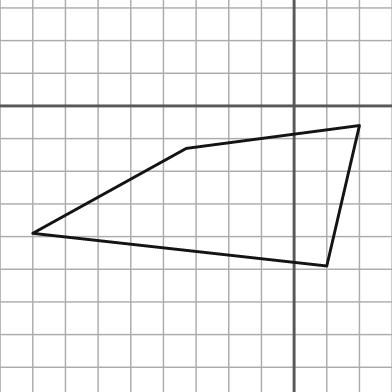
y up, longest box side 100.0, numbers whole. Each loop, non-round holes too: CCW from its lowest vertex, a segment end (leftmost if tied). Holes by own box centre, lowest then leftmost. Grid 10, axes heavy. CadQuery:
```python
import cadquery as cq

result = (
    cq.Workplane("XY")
    .moveTo(10.0, -49.0)
    .lineTo(20.0, -6.0)
    .lineTo(-33.0, -13.0)
    .lineTo(-80.0, -39.0)
    .close()
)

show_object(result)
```